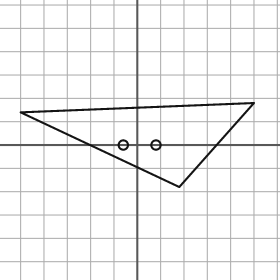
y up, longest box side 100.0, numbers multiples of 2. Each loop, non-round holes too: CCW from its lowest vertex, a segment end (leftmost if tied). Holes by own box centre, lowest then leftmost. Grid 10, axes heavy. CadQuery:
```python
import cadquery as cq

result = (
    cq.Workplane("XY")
    .moveTo(18.0, -18.0)
    .lineTo(50.0, 18.0)
    .lineTo(-50.0, 14.0)
    .close()
    .moveTo(-6.0, 0.0)
    .circle(2.0)
    .moveTo(8.0, 0.0)
    .circle(2.0)
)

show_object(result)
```